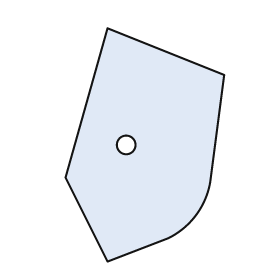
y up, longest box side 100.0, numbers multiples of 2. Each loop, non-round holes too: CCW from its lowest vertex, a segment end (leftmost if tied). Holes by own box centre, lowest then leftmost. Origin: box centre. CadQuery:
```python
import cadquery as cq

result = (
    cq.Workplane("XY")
    .moveTo(-16.0, -50.0)
    .lineTo(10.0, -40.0)
    .threePointArc((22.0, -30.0), (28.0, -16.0))
    .lineTo(34.0, 30.0)
    .lineTo(-16.0, 50.0)
    .lineTo(-34.0, -14.0)
    .close()
    .moveTo(-8.0, 0.0)
    .circle(4.0)
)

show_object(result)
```